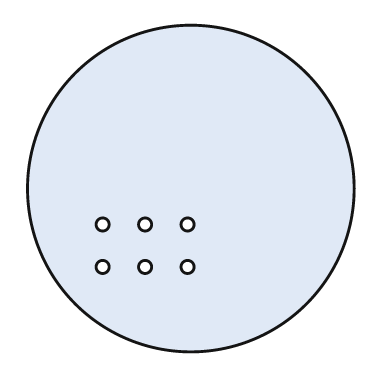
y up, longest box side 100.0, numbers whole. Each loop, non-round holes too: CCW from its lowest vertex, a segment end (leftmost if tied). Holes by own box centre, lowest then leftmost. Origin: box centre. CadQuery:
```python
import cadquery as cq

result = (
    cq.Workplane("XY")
    .moveTo(0.0, 0.0)
    .circle(50.0)
    .moveTo(-27.0, -24.0)
    .circle(2.0)
    .moveTo(-14.0, -24.0)
    .circle(2.0)
    .moveTo(-1.0, -24.0)
    .circle(2.0)
    .moveTo(-27.0, -11.0)
    .circle(2.0)
    .moveTo(-14.0, -11.0)
    .circle(2.0)
    .moveTo(-1.0, -11.0)
    .circle(2.0)
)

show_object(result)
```